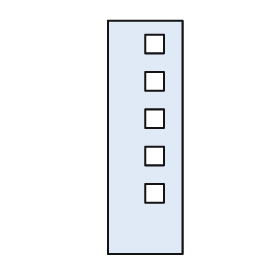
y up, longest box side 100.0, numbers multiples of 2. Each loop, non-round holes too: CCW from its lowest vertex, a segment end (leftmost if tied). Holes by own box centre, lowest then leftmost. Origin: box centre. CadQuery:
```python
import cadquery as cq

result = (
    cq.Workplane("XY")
    .moveTo(-16.0, -50.0)
    .lineTo(16.0, -50.0)
    .lineTo(16.0, 50.0)
    .lineTo(-16.0, 50.0)
    .close()
    .moveTo(0.0, -28.0)
    .lineTo(8.0, -28.0)
    .lineTo(8.0, -20.0)
    .lineTo(0.0, -20.0)
    .close()
    .moveTo(0.0, -12.0)
    .lineTo(8.0, -12.0)
    .lineTo(8.0, -4.0)
    .lineTo(0.0, -4.0)
    .close()
    .moveTo(0.0, 4.0)
    .lineTo(8.0, 4.0)
    .lineTo(8.0, 12.0)
    .lineTo(0.0, 12.0)
    .close()
    .moveTo(0.0, 20.0)
    .lineTo(8.0, 20.0)
    .lineTo(8.0, 28.0)
    .lineTo(0.0, 28.0)
    .close()
    .moveTo(0.0, 36.0)
    .lineTo(8.0, 36.0)
    .lineTo(8.0, 44.0)
    .lineTo(0.0, 44.0)
    .close()
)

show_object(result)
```